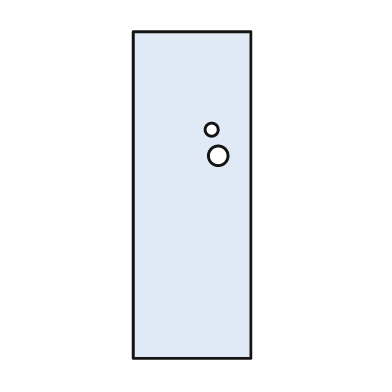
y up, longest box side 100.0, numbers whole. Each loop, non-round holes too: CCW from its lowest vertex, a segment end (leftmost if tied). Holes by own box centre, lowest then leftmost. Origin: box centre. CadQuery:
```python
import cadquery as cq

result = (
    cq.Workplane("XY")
    .moveTo(-18.0, -50.0)
    .lineTo(18.0, -50.0)
    .lineTo(18.0, 50.0)
    .lineTo(-18.0, 50.0)
    .close()
    .moveTo(8.0, 12.0)
    .circle(3.0)
    .moveTo(6.0, 20.0)
    .circle(2.0)
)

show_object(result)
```